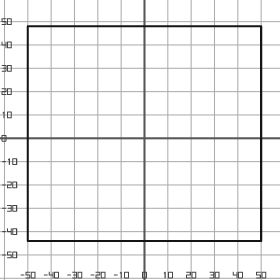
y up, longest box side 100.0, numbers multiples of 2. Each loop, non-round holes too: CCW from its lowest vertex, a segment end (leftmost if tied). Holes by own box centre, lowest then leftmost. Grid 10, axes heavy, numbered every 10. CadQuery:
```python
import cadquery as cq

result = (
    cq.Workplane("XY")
    .moveTo(-50.0, -44.0)
    .lineTo(50.0, -44.0)
    .lineTo(50.0, 48.0)
    .lineTo(-50.0, 48.0)
    .close()
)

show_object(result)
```